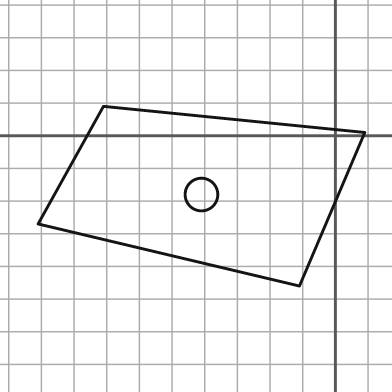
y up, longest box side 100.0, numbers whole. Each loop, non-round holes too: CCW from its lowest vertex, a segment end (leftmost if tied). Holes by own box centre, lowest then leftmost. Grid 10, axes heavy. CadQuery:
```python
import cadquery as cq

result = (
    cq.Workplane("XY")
    .moveTo(-11.0, -46.0)
    .lineTo(9.0, 1.0)
    .lineTo(-71.0, 9.0)
    .lineTo(-91.0, -27.0)
    .close()
    .moveTo(-41.0, -18.0)
    .circle(5.0)
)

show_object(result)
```